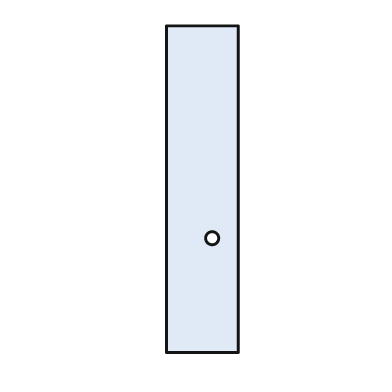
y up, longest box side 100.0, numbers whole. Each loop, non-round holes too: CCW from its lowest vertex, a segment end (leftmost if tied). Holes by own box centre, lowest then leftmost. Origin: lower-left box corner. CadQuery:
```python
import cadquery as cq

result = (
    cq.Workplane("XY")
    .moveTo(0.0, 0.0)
    .lineTo(22.0, 0.0)
    .lineTo(22.0, 100.0)
    .lineTo(0.0, 100.0)
    .close()
    .moveTo(14.0, 35.0)
    .circle(2.0)
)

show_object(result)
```